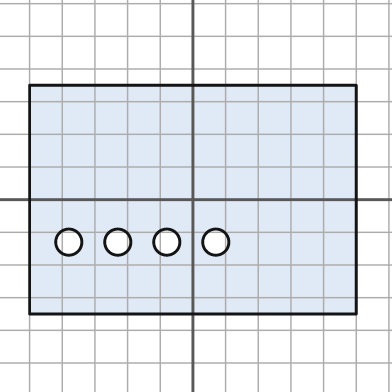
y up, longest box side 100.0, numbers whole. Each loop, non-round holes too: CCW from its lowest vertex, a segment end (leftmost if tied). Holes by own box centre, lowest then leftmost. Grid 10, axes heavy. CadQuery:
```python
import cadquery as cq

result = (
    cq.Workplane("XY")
    .moveTo(-50.0, -35.0)
    .lineTo(50.0, -35.0)
    .lineTo(50.0, 35.0)
    .lineTo(-50.0, 35.0)
    .close()
    .moveTo(-38.0, -13.0)
    .circle(4.0)
    .moveTo(-23.0, -13.0)
    .circle(4.0)
    .moveTo(-8.0, -13.0)
    .circle(4.0)
    .moveTo(7.0, -13.0)
    .circle(4.0)
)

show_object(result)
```